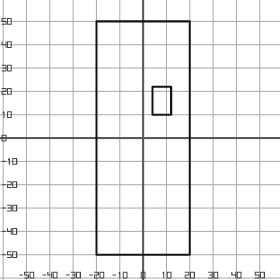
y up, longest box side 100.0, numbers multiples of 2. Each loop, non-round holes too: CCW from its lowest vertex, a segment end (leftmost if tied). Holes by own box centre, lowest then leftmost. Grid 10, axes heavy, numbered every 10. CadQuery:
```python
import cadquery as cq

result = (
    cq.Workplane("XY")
    .moveTo(-20.0, -50.0)
    .lineTo(20.0, -50.0)
    .lineTo(20.0, 50.0)
    .lineTo(-20.0, 50.0)
    .close()
    .moveTo(4.0, 10.0)
    .lineTo(12.0, 10.0)
    .lineTo(12.0, 22.0)
    .lineTo(4.0, 22.0)
    .close()
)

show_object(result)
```